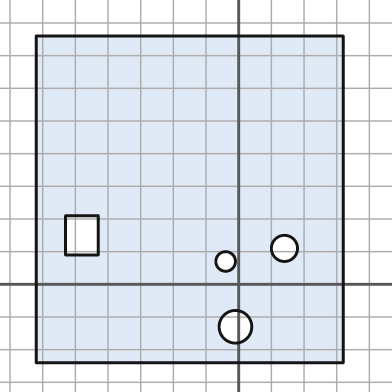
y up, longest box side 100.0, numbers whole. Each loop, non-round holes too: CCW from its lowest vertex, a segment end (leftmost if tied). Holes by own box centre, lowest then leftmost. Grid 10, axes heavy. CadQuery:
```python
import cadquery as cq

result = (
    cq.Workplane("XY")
    .moveTo(-62.0, -24.0)
    .lineTo(32.0, -24.0)
    .lineTo(32.0, 76.0)
    .lineTo(-62.0, 76.0)
    .close()
    .moveTo(-1.0, -13.0)
    .circle(5.0)
    .moveTo(-4.0, 7.0)
    .circle(3.0)
    .moveTo(14.0, 11.0)
    .circle(4.0)
    .moveTo(-53.0, 9.0)
    .lineTo(-43.0, 9.0)
    .lineTo(-43.0, 21.0)
    .lineTo(-53.0, 21.0)
    .close()
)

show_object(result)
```